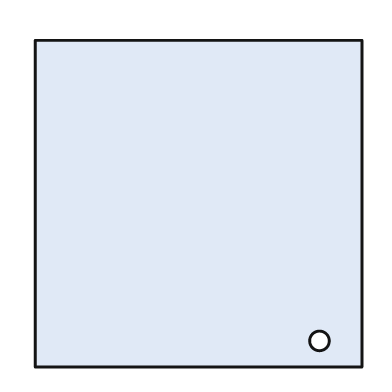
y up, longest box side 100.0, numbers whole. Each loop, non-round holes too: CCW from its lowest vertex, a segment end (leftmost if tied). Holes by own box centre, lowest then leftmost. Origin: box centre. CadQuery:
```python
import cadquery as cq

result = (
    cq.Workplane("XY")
    .moveTo(-50.0, -50.0)
    .lineTo(50.0, -50.0)
    .lineTo(50.0, 50.0)
    .lineTo(-50.0, 50.0)
    .close()
    .moveTo(37.0, -42.0)
    .circle(3.0)
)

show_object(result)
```